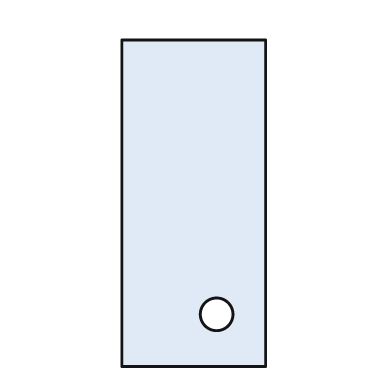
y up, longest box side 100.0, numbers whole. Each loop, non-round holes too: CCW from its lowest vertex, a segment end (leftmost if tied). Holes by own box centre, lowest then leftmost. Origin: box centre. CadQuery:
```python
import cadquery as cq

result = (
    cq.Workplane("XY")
    .moveTo(-22.0, -50.0)
    .lineTo(22.0, -50.0)
    .lineTo(22.0, 50.0)
    .lineTo(-22.0, 50.0)
    .close()
    .moveTo(7.0, -34.0)
    .circle(5.0)
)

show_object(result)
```